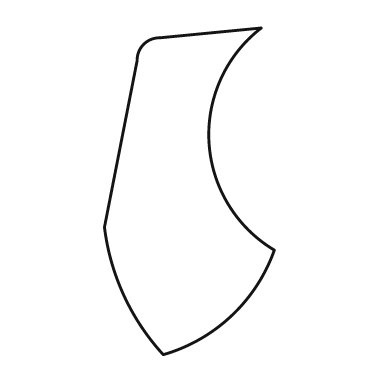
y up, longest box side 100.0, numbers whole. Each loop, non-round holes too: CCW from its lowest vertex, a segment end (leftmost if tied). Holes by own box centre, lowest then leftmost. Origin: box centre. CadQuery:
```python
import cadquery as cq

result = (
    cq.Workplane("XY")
    .moveTo(-8.0, -50.0)
    .threePointArc((13.0, -38.0), (26.0, -18.0))
    .threePointArc((6.0, 15.0), (22.0, 50.0))
    .lineTo(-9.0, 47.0)
    .threePointArc((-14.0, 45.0), (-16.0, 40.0))
    .lineTo(-26.0, -11.0)
    .threePointArc((-20.0, -32.0), (-8.0, -50.0))
    .close()
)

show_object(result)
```